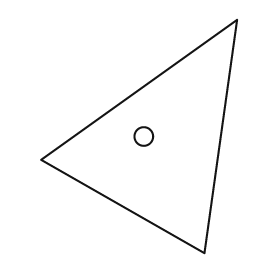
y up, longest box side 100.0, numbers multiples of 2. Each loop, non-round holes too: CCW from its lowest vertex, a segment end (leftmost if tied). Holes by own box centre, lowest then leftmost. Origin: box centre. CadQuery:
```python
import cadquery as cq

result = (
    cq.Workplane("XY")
    .moveTo(28.0, -50.0)
    .lineTo(42.0, 50.0)
    .lineTo(-42.0, -10.0)
    .close()
    .moveTo(2.0, 0.0)
    .circle(4.0)
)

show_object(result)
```